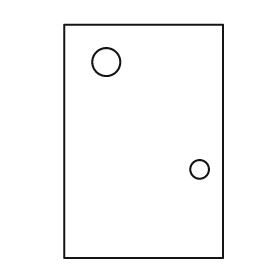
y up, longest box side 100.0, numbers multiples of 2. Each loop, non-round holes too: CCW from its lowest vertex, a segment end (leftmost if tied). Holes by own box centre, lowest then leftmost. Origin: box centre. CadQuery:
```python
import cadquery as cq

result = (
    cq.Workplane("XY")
    .moveTo(-34.0, -50.0)
    .lineTo(34.0, -50.0)
    .lineTo(34.0, 50.0)
    .lineTo(-34.0, 50.0)
    .close()
    .moveTo(24.0, -12.0)
    .circle(4.0)
    .moveTo(-16.0, 34.0)
    .circle(6.0)
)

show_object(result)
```